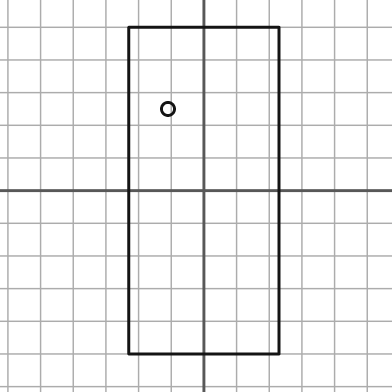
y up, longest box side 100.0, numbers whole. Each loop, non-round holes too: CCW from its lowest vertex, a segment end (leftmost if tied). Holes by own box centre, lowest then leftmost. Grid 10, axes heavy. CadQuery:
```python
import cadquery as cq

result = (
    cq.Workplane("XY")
    .moveTo(-23.0, -50.0)
    .lineTo(23.0, -50.0)
    .lineTo(23.0, 50.0)
    .lineTo(-23.0, 50.0)
    .close()
    .moveTo(-11.0, 25.0)
    .circle(2.0)
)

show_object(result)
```